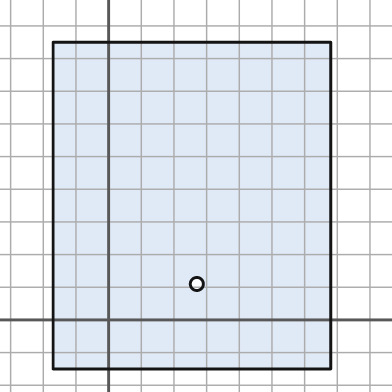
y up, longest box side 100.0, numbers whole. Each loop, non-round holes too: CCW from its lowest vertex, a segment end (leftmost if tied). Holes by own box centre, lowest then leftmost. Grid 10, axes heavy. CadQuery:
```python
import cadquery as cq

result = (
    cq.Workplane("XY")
    .moveTo(-17.0, -15.0)
    .lineTo(68.0, -15.0)
    .lineTo(68.0, 85.0)
    .lineTo(-17.0, 85.0)
    .close()
    .moveTo(27.0, 11.0)
    .circle(2.0)
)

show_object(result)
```